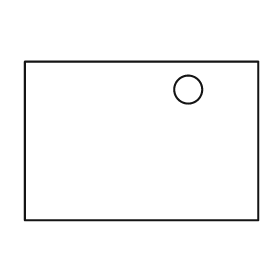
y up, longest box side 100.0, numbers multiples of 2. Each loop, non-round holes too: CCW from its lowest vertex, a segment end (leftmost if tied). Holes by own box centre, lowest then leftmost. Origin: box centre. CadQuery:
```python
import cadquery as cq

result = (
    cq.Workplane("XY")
    .moveTo(-50.0, -34.0)
    .lineTo(50.0, -34.0)
    .lineTo(50.0, 34.0)
    .lineTo(-50.0, 34.0)
    .close()
    .moveTo(20.0, 22.0)
    .circle(6.0)
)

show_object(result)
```